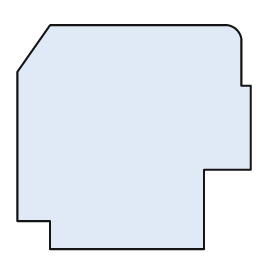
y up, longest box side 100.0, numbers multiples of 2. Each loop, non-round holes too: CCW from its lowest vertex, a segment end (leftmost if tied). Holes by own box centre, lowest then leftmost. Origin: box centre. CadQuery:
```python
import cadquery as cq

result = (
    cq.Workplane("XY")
    .moveTo(-36.0, -48.0)
    .lineTo(30.0, -48.0)
    .lineTo(30.0, -14.0)
    .lineTo(50.0, -14.0)
    .lineTo(50.0, 22.0)
    .lineTo(46.0, 22.0)
    .lineTo(46.0, 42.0)
    .threePointArc((44.0, 46.0), (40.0, 48.0))
    .lineTo(-36.0, 48.0)
    .lineTo(-50.0, 28.0)
    .lineTo(-50.0, -36.0)
    .lineTo(-36.0, -36.0)
    .close()
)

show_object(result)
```